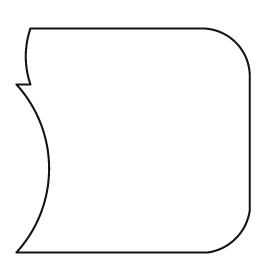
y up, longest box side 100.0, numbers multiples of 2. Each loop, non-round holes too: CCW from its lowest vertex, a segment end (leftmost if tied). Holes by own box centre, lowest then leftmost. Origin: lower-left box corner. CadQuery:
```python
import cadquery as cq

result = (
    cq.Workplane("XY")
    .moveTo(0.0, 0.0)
    .lineTo(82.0, 0.0)
    .threePointArc((94.0, 6.0), (100.0, 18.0))
    .lineTo(100.0, 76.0)
    .threePointArc((94.0, 90.0), (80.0, 96.0))
    .lineTo(6.0, 96.0)
    .threePointArc((4.0, 84.0), (6.0, 72.0))
    .lineTo(0.0, 72.0)
    .threePointArc((14.0, 36.0), (0.0, 0.0))
    .close()
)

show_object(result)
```